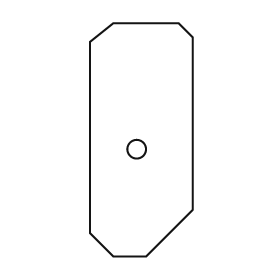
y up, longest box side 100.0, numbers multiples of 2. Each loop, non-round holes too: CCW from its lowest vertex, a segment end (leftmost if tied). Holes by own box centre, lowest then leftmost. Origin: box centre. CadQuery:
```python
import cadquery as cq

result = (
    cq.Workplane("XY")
    .moveTo(-12.0, -50.0)
    .lineTo(2.0, -50.0)
    .lineTo(22.0, -30.0)
    .lineTo(22.0, 44.0)
    .lineTo(16.0, 50.0)
    .lineTo(-12.0, 50.0)
    .lineTo(-22.0, 42.0)
    .lineTo(-22.0, -40.0)
    .close()
    .moveTo(-2.0, -4.0)
    .circle(4.0)
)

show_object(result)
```